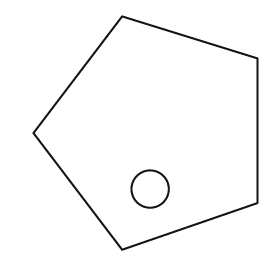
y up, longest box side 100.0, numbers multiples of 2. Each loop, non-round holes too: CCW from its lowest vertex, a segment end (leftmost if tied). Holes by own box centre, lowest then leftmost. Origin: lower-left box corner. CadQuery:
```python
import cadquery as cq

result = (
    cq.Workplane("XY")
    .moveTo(38.0, 0.0)
    .lineTo(96.0, 20.0)
    .lineTo(96.0, 82.0)
    .lineTo(38.0, 100.0)
    .lineTo(0.0, 50.0)
    .close()
    .moveTo(50.0, 26.0)
    .circle(8.0)
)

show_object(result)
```